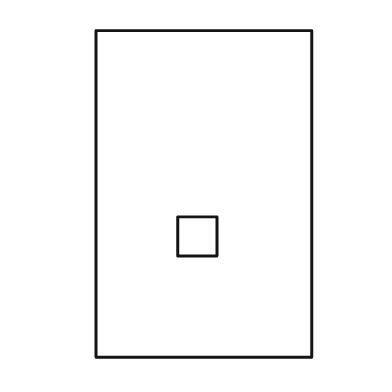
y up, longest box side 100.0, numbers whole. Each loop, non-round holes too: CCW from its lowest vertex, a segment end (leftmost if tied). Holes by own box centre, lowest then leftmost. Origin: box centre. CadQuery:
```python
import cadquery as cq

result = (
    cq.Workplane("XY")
    .moveTo(-33.0, -50.0)
    .lineTo(33.0, -50.0)
    .lineTo(33.0, 50.0)
    .lineTo(-33.0, 50.0)
    .close()
    .moveTo(-8.0, -19.0)
    .lineTo(4.0, -19.0)
    .lineTo(4.0, -7.0)
    .lineTo(-8.0, -7.0)
    .close()
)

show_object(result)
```